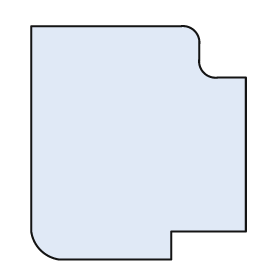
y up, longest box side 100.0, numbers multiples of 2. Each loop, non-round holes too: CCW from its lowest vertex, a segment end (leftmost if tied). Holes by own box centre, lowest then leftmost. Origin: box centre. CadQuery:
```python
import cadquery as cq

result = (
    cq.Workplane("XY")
    .moveTo(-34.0, -50.0)
    .lineTo(14.0, -50.0)
    .lineTo(14.0, -38.0)
    .lineTo(46.0, -38.0)
    .lineTo(46.0, 28.0)
    .lineTo(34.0, 28.0)
    .threePointArc((28.0, 30.0), (26.0, 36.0))
    .lineTo(26.0, 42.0)
    .threePointArc((24.0, 48.0), (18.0, 50.0))
    .lineTo(-46.0, 50.0)
    .lineTo(-46.0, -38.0)
    .threePointArc((-42.0, -46.0), (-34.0, -50.0))
    .close()
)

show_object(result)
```